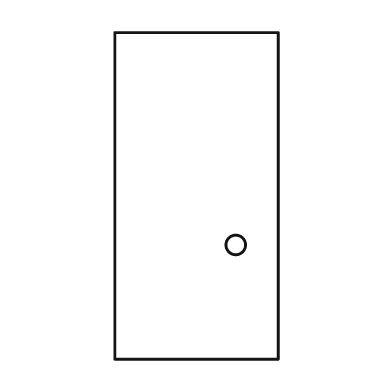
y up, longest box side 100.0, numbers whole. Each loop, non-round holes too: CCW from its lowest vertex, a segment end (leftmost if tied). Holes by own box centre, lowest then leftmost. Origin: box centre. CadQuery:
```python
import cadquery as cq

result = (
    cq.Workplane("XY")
    .moveTo(-25.0, -50.0)
    .lineTo(25.0, -50.0)
    .lineTo(25.0, 50.0)
    .lineTo(-25.0, 50.0)
    .close()
    .moveTo(12.0, -15.0)
    .circle(3.0)
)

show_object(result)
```